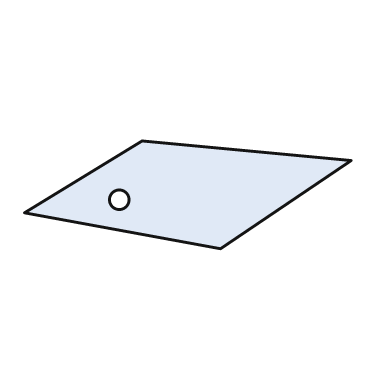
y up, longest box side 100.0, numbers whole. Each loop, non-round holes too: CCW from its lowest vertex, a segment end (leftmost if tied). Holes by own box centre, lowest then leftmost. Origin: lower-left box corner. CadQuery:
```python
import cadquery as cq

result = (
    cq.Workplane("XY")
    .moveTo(60.0, 0.0)
    .lineTo(100.0, 27.0)
    .lineTo(36.0, 33.0)
    .lineTo(0.0, 11.0)
    .close()
    .moveTo(29.0, 15.0)
    .circle(3.0)
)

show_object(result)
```